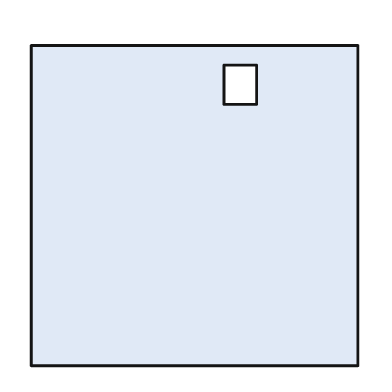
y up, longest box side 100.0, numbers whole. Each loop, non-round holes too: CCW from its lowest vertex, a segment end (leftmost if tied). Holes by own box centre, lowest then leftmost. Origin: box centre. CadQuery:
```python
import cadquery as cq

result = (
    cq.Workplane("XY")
    .moveTo(-50.0, -49.0)
    .lineTo(50.0, -49.0)
    .lineTo(50.0, 49.0)
    .lineTo(-50.0, 49.0)
    .close()
    .moveTo(9.0, 31.0)
    .lineTo(19.0, 31.0)
    .lineTo(19.0, 43.0)
    .lineTo(9.0, 43.0)
    .close()
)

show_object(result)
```